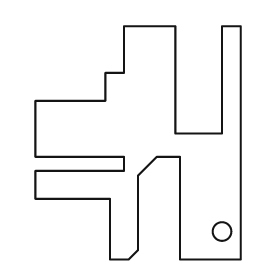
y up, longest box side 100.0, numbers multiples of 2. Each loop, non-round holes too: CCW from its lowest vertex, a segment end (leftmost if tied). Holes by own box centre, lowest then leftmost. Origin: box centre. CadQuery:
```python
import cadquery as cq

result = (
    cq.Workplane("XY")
    .moveTo(-12.0, -50.0)
    .lineTo(-4.0, -50.0)
    .lineTo(0.0, -46.0)
    .lineTo(0.0, -14.0)
    .lineTo(8.0, -6.0)
    .lineTo(18.0, -6.0)
    .lineTo(18.0, -50.0)
    .lineTo(44.0, -50.0)
    .lineTo(44.0, 50.0)
    .lineTo(36.0, 50.0)
    .lineTo(36.0, 4.0)
    .lineTo(16.0, 4.0)
    .lineTo(16.0, 50.0)
    .lineTo(-6.0, 50.0)
    .lineTo(-6.0, 30.0)
    .lineTo(-14.0, 30.0)
    .lineTo(-14.0, 18.0)
    .lineTo(-44.0, 18.0)
    .lineTo(-44.0, -6.0)
    .lineTo(-6.0, -6.0)
    .lineTo(-6.0, -12.0)
    .lineTo(-44.0, -12.0)
    .lineTo(-44.0, -24.0)
    .lineTo(-12.0, -24.0)
    .close()
    .moveTo(36.0, -38.0)
    .circle(4.0)
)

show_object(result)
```